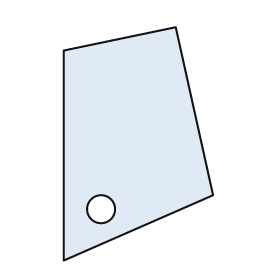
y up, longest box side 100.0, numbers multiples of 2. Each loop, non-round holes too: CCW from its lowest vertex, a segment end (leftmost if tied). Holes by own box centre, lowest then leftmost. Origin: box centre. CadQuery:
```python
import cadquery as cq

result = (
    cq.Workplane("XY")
    .moveTo(-32.0, -50.0)
    .lineTo(32.0, -22.0)
    .lineTo(16.0, 50.0)
    .lineTo(-32.0, 40.0)
    .close()
    .moveTo(-16.0, -28.0)
    .circle(6.0)
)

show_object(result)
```